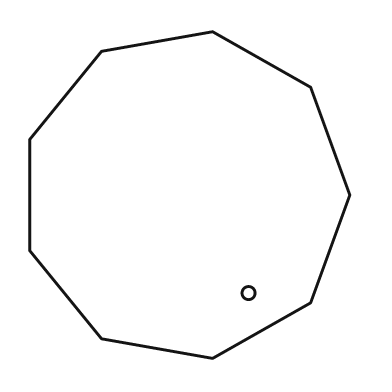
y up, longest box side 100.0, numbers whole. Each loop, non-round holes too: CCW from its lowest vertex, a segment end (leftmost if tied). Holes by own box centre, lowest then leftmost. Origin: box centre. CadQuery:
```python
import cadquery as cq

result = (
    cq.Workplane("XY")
    .moveTo(7.0, -50.0)
    .lineTo(37.0, -33.0)
    .lineTo(49.0, 0.0)
    .lineTo(37.0, 33.0)
    .lineTo(7.0, 50.0)
    .lineTo(-27.0, 44.0)
    .lineTo(-49.0, 17.0)
    .lineTo(-49.0, -17.0)
    .lineTo(-27.0, -44.0)
    .close()
    .moveTo(18.0, -30.0)
    .circle(2.0)
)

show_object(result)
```